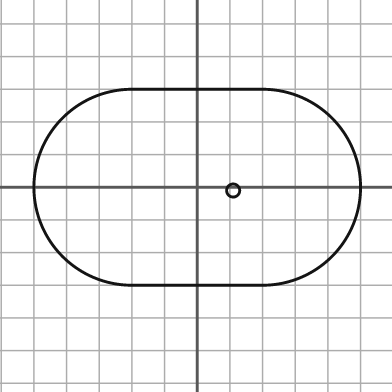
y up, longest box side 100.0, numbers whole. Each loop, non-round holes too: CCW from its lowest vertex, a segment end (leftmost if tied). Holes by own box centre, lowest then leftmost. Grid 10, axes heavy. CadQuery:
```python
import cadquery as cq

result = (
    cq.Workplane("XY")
    .moveTo(-20.0, -30.0)
    .lineTo(20.0, -30.0)
    .threePointArc((50.0, 0.0), (20.0, 30.0))
    .lineTo(-20.0, 30.0)
    .threePointArc((-50.0, 0.0), (-20.0, -30.0))
    .close()
    .moveTo(11.0, -1.0)
    .circle(2.0)
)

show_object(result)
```